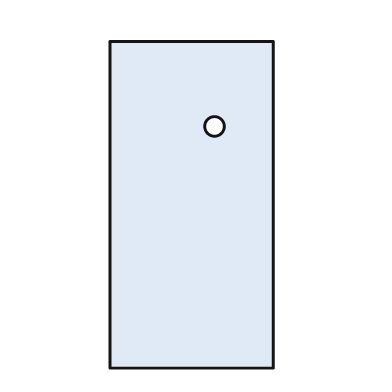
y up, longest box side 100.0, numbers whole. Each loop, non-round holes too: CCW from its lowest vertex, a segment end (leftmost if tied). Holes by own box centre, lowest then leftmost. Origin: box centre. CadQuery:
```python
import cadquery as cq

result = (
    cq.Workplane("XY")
    .moveTo(-25.0, -50.0)
    .lineTo(25.0, -50.0)
    .lineTo(25.0, 50.0)
    .lineTo(-25.0, 50.0)
    .close()
    .moveTo(7.0, 24.0)
    .circle(3.0)
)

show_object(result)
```